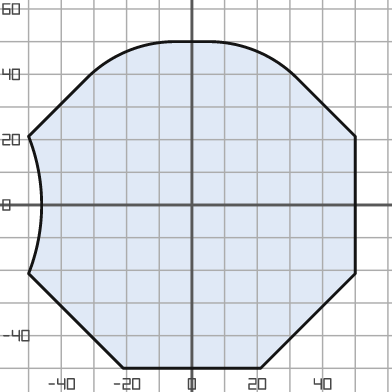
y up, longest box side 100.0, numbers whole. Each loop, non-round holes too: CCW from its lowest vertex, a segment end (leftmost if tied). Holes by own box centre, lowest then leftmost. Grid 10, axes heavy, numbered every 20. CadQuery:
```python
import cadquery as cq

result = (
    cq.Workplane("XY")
    .moveTo(-21.0, -50.0)
    .lineTo(21.0, -50.0)
    .lineTo(50.0, -21.0)
    .lineTo(50.0, 21.0)
    .lineTo(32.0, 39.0)
    .threePointArc((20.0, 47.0), (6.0, 50.0))
    .lineTo(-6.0, 50.0)
    .threePointArc((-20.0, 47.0), (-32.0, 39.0))
    .lineTo(-50.0, 21.0)
    .threePointArc((-46.0, 0.0), (-50.0, -21.0))
    .close()
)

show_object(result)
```